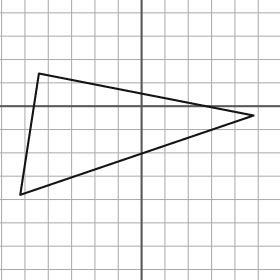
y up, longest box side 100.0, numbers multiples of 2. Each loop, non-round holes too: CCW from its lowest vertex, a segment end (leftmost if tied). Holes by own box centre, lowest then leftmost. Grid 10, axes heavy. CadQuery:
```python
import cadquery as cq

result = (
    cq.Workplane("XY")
    .moveTo(-52.0, -38.0)
    .lineTo(48.0, -4.0)
    .lineTo(-44.0, 14.0)
    .close()
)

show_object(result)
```